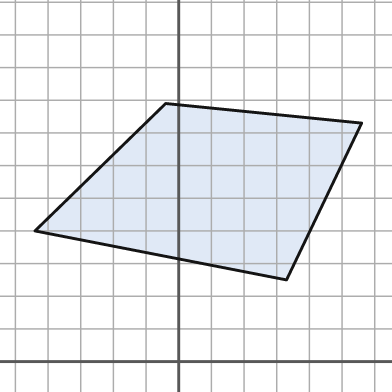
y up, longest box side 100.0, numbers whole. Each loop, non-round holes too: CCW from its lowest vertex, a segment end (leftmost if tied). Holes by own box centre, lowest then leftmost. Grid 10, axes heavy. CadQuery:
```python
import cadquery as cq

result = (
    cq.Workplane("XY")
    .moveTo(33.0, 25.0)
    .lineTo(56.0, 73.0)
    .lineTo(-4.0, 79.0)
    .lineTo(-44.0, 40.0)
    .close()
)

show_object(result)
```